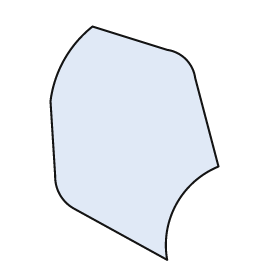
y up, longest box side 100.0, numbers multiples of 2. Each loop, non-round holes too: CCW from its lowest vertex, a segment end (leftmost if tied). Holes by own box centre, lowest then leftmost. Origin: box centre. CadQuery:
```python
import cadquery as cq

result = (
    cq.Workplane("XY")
    .moveTo(14.0, -50.0)
    .threePointArc((18.0, -26.0), (36.0, -10.0))
    .lineTo(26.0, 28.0)
    .threePointArc((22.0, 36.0), (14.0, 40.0))
    .lineTo(-18.0, 50.0)
    .threePointArc((-30.0, 36.0), (-36.0, 18.0))
    .lineTo(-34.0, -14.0)
    .threePointArc((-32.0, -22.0), (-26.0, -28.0))
    .close()
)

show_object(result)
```